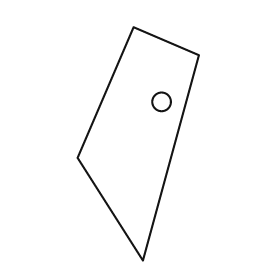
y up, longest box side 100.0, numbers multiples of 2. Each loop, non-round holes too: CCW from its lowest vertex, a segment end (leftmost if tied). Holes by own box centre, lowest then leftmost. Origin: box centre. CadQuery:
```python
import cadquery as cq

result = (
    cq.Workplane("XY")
    .moveTo(2.0, -50.0)
    .lineTo(26.0, 38.0)
    .lineTo(-2.0, 50.0)
    .lineTo(-26.0, -6.0)
    .close()
    .moveTo(10.0, 18.0)
    .circle(4.0)
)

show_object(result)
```